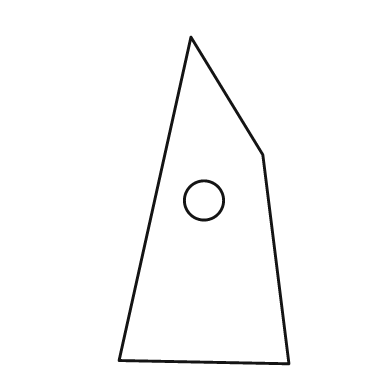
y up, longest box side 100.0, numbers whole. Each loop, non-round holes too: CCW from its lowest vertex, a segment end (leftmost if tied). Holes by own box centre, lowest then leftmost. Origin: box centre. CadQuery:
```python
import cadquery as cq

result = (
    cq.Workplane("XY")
    .moveTo(26.0, -50.0)
    .lineTo(18.0, 14.0)
    .lineTo(-4.0, 50.0)
    .lineTo(-26.0, -49.0)
    .close()
    .moveTo(0.0, 0.0)
    .circle(6.0)
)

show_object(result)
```